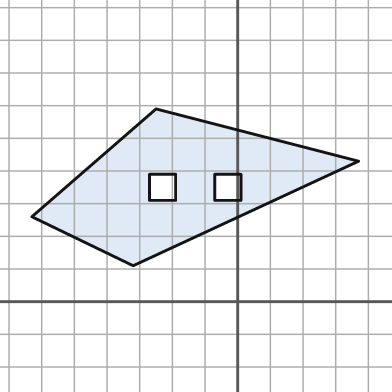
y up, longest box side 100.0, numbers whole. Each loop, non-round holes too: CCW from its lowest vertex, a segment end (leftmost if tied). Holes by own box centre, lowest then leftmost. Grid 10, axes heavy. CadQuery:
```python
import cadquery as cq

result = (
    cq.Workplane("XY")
    .moveTo(-32.0, 11.0)
    .lineTo(37.0, 43.0)
    .lineTo(-25.0, 59.0)
    .lineTo(-63.0, 26.0)
    .close()
    .moveTo(-27.0, 31.0)
    .lineTo(-19.0, 31.0)
    .lineTo(-19.0, 39.0)
    .lineTo(-27.0, 39.0)
    .close()
    .moveTo(-7.0, 31.0)
    .lineTo(1.0, 31.0)
    .lineTo(1.0, 39.0)
    .lineTo(-7.0, 39.0)
    .close()
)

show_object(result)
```